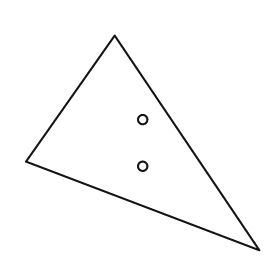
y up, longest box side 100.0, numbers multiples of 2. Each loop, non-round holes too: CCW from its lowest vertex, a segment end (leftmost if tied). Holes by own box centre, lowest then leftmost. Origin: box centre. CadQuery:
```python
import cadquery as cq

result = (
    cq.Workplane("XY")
    .moveTo(50.0, -46.0)
    .lineTo(-12.0, 46.0)
    .lineTo(-50.0, -8.0)
    .close()
    .moveTo(0.0, -10.0)
    .circle(2.0)
    .moveTo(0.0, 10.0)
    .circle(2.0)
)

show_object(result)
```